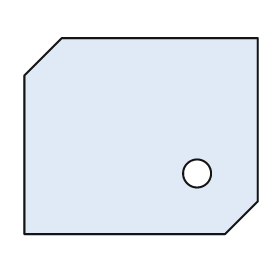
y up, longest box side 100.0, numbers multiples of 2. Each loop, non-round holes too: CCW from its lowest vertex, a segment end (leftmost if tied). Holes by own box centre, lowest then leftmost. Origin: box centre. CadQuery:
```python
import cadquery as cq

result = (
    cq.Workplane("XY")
    .moveTo(-50.0, -42.0)
    .lineTo(36.0, -42.0)
    .lineTo(50.0, -28.0)
    .lineTo(50.0, 42.0)
    .lineTo(-34.0, 42.0)
    .lineTo(-50.0, 26.0)
    .close()
    .moveTo(24.0, -16.0)
    .circle(6.0)
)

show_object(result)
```